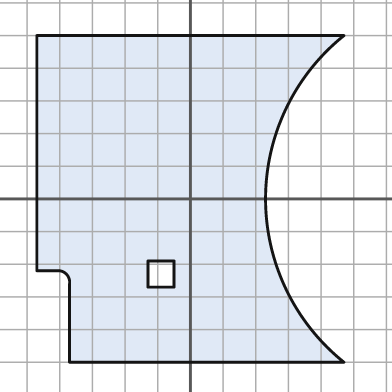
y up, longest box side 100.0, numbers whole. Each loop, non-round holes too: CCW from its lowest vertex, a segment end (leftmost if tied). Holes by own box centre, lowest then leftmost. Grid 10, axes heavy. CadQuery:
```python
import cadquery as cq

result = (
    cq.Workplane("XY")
    .moveTo(-37.0, -50.0)
    .lineTo(47.0, -50.0)
    .threePointArc((23.0, 0.0), (47.0, 50.0))
    .lineTo(-47.0, 50.0)
    .lineTo(-47.0, -22.0)
    .lineTo(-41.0, -22.0)
    .threePointArc((-38.0, -23.0), (-37.0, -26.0))
    .close()
    .moveTo(-13.0, -27.0)
    .lineTo(-5.0, -27.0)
    .lineTo(-5.0, -19.0)
    .lineTo(-13.0, -19.0)
    .close()
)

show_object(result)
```